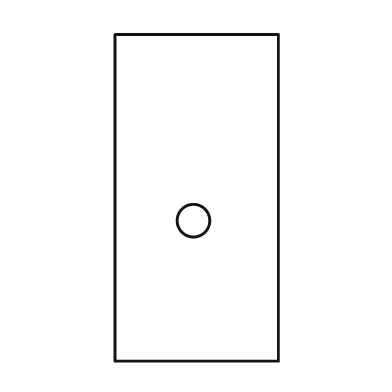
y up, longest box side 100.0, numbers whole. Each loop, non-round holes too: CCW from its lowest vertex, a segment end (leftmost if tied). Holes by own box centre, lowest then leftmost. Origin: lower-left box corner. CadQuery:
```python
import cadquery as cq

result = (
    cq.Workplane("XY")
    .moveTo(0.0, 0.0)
    .lineTo(50.0, 0.0)
    .lineTo(50.0, 100.0)
    .lineTo(0.0, 100.0)
    .close()
    .moveTo(24.0, 43.0)
    .circle(5.0)
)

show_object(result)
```